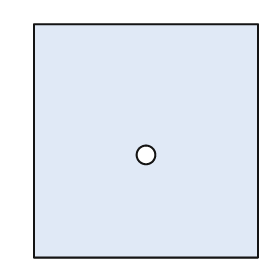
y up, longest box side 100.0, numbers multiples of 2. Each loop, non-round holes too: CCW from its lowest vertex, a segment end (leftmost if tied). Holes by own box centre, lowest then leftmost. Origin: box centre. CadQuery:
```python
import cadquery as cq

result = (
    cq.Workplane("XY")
    .moveTo(-48.0, -50.0)
    .lineTo(48.0, -50.0)
    .lineTo(48.0, 50.0)
    .lineTo(-48.0, 50.0)
    .close()
    .moveTo(0.0, -6.0)
    .circle(4.0)
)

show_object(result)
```